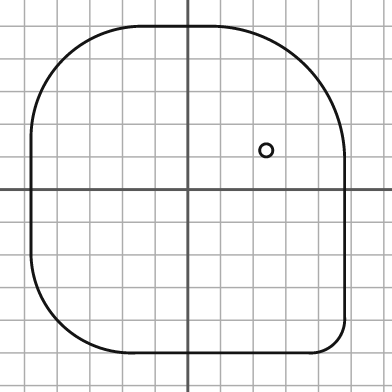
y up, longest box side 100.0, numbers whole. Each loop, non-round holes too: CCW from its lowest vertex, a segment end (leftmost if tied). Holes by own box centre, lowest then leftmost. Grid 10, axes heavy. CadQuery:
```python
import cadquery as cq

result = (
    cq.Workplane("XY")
    .moveTo(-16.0, -50.0)
    .lineTo(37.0, -50.0)
    .threePointArc((45.0, -47.0), (48.0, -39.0))
    .lineTo(48.0, 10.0)
    .threePointArc((36.0, 38.0), (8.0, 50.0))
    .lineTo(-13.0, 50.0)
    .threePointArc((-38.0, 40.0), (-48.0, 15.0))
    .lineTo(-48.0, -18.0)
    .threePointArc((-39.0, -41.0), (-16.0, -50.0))
    .close()
    .moveTo(24.0, 12.0)
    .circle(2.0)
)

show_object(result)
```